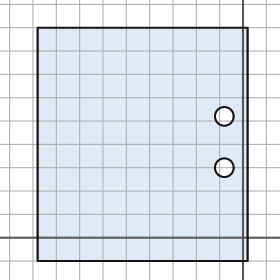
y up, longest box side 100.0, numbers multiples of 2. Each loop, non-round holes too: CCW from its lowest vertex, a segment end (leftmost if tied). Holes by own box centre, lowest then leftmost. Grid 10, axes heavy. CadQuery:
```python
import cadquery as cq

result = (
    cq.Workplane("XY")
    .moveTo(-88.0, -10.0)
    .lineTo(2.0, -10.0)
    .lineTo(2.0, 90.0)
    .lineTo(-88.0, 90.0)
    .close()
    .moveTo(-8.0, 30.0)
    .circle(4.0)
    .moveTo(-8.0, 52.0)
    .circle(4.0)
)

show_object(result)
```